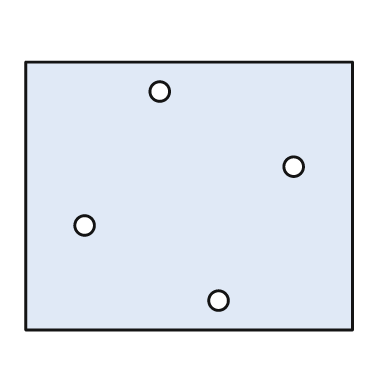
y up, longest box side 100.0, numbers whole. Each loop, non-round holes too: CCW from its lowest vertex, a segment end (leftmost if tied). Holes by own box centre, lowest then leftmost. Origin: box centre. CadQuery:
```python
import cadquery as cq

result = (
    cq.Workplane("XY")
    .moveTo(-50.0, -41.0)
    .lineTo(50.0, -41.0)
    .lineTo(50.0, 41.0)
    .lineTo(-50.0, 41.0)
    .close()
    .moveTo(9.0, -32.0)
    .circle(3.0)
    .moveTo(-32.0, -9.0)
    .circle(3.0)
    .moveTo(32.0, 9.0)
    .circle(3.0)
    .moveTo(-9.0, 32.0)
    .circle(3.0)
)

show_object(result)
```